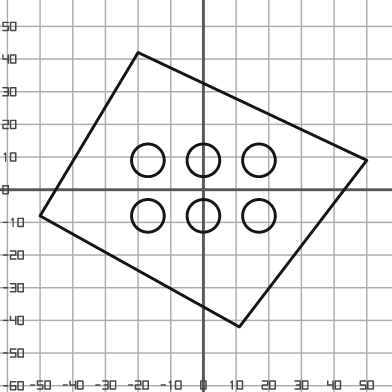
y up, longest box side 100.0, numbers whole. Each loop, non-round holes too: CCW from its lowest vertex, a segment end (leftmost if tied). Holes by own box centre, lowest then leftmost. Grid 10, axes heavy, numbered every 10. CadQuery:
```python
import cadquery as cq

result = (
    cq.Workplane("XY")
    .moveTo(11.0, -42.0)
    .lineTo(50.0, 9.0)
    .lineTo(-20.0, 42.0)
    .lineTo(-50.0, -8.0)
    .close()
    .moveTo(-17.0, -8.0)
    .circle(5.0)
    .moveTo(0.0, -8.0)
    .circle(5.0)
    .moveTo(17.0, -8.0)
    .circle(5.0)
    .moveTo(-17.0, 9.0)
    .circle(5.0)
    .moveTo(0.0, 9.0)
    .circle(5.0)
    .moveTo(17.0, 9.0)
    .circle(5.0)
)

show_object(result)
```